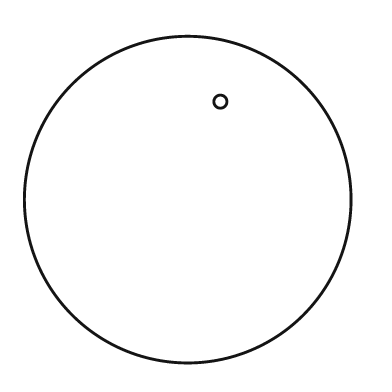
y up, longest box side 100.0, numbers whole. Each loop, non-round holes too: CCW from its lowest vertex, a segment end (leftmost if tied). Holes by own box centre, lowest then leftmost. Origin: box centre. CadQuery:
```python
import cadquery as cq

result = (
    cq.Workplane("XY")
    .moveTo(0.0, 0.0)
    .circle(50.0)
    .moveTo(10.0, 30.0)
    .circle(2.0)
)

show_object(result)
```